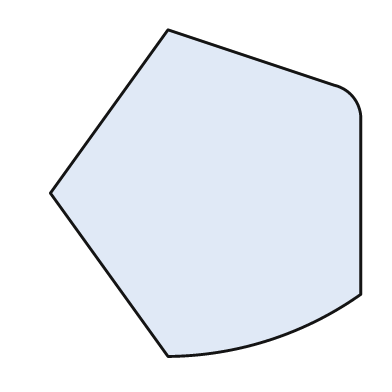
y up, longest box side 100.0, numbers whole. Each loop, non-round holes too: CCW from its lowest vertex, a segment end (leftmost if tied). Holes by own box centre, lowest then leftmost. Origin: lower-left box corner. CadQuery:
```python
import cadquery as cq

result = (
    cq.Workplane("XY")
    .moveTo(36.0, 0.0)
    .threePointArc((67.0, 5.0), (95.0, 19.0))
    .lineTo(95.0, 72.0)
    .threePointArc((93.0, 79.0), (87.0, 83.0))
    .lineTo(36.0, 100.0)
    .lineTo(0.0, 50.0)
    .close()
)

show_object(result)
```